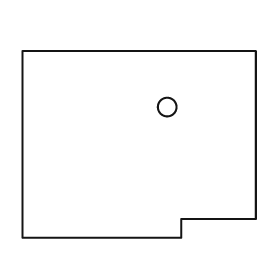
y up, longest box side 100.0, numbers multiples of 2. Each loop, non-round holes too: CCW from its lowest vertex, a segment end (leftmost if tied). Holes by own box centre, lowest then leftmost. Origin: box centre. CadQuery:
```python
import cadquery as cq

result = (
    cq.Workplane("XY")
    .moveTo(-50.0, -40.0)
    .lineTo(18.0, -40.0)
    .lineTo(18.0, -32.0)
    .lineTo(50.0, -32.0)
    .lineTo(50.0, 40.0)
    .lineTo(-50.0, 40.0)
    .close()
    .moveTo(12.0, 16.0)
    .circle(4.0)
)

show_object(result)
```